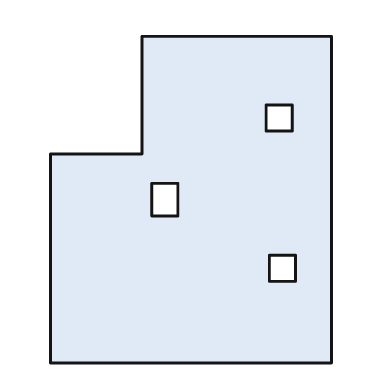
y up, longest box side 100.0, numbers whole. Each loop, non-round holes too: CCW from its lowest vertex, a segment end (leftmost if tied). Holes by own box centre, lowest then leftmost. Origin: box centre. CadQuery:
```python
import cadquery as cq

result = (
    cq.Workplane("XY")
    .moveTo(-43.0, -50.0)
    .lineTo(43.0, -50.0)
    .lineTo(43.0, 50.0)
    .lineTo(-15.0, 50.0)
    .lineTo(-15.0, 14.0)
    .lineTo(-43.0, 14.0)
    .close()
    .moveTo(24.0, -25.0)
    .lineTo(32.0, -25.0)
    .lineTo(32.0, -17.0)
    .lineTo(24.0, -17.0)
    .close()
    .moveTo(-12.0, -5.0)
    .lineTo(-4.0, -5.0)
    .lineTo(-4.0, 5.0)
    .lineTo(-12.0, 5.0)
    .close()
    .moveTo(23.0, 21.0)
    .lineTo(31.0, 21.0)
    .lineTo(31.0, 29.0)
    .lineTo(23.0, 29.0)
    .close()
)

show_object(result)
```